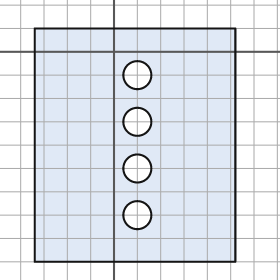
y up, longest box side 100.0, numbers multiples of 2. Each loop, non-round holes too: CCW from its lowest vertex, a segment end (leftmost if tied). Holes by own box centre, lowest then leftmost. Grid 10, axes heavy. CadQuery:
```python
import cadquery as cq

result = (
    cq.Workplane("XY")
    .moveTo(-34.0, -90.0)
    .lineTo(52.0, -90.0)
    .lineTo(52.0, 10.0)
    .lineTo(-34.0, 10.0)
    .close()
    .moveTo(10.0, -70.0)
    .circle(6.0)
    .moveTo(10.0, -50.0)
    .circle(6.0)
    .moveTo(10.0, -30.0)
    .circle(6.0)
    .moveTo(10.0, -10.0)
    .circle(6.0)
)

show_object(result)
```